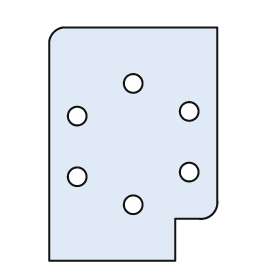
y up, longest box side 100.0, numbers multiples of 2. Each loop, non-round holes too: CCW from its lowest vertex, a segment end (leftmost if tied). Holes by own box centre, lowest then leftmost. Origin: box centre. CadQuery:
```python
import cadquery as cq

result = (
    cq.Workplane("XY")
    .moveTo(-36.0, -50.0)
    .lineTo(18.0, -50.0)
    .lineTo(18.0, -32.0)
    .lineTo(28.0, -32.0)
    .threePointArc((34.0, -30.0), (36.0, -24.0))
    .lineTo(36.0, 50.0)
    .lineTo(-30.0, 50.0)
    .threePointArc((-34.0, 48.0), (-36.0, 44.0))
    .close()
    .moveTo(0.0, -26.0)
    .circle(4.0)
    .moveTo(-24.0, -14.0)
    .circle(4.0)
    .moveTo(24.0, -12.0)
    .circle(4.0)
    .moveTo(-24.0, 12.0)
    .circle(4.0)
    .moveTo(24.0, 14.0)
    .circle(4.0)
    .moveTo(0.0, 26.0)
    .circle(4.0)
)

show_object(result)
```